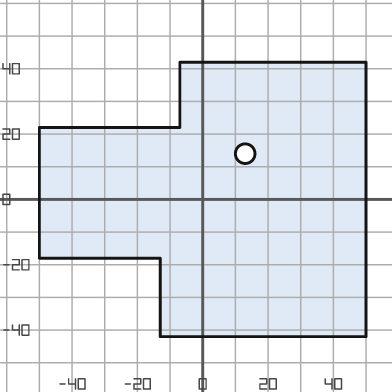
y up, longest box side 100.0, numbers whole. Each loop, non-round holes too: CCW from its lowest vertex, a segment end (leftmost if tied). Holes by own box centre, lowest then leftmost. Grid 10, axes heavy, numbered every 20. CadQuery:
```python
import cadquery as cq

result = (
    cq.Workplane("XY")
    .moveTo(-13.0, -42.0)
    .lineTo(50.0, -42.0)
    .lineTo(50.0, 42.0)
    .lineTo(-7.0, 42.0)
    .lineTo(-7.0, 22.0)
    .lineTo(-50.0, 22.0)
    .lineTo(-50.0, -18.0)
    .lineTo(-13.0, -18.0)
    .close()
    .moveTo(13.0, 14.0)
    .circle(3.0)
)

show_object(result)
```